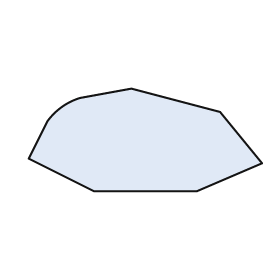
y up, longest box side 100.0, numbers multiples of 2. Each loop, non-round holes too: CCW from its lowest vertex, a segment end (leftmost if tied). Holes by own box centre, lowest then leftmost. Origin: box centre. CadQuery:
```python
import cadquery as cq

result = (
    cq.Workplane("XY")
    .moveTo(-22.0, -22.0)
    .lineTo(22.0, -22.0)
    .lineTo(50.0, -10.0)
    .lineTo(32.0, 12.0)
    .lineTo(-6.0, 22.0)
    .lineTo(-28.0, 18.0)
    .threePointArc((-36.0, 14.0), (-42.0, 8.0))
    .lineTo(-50.0, -8.0)
    .close()
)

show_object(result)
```